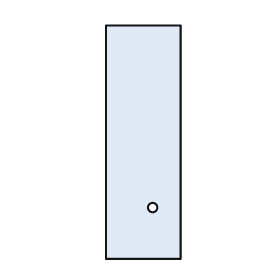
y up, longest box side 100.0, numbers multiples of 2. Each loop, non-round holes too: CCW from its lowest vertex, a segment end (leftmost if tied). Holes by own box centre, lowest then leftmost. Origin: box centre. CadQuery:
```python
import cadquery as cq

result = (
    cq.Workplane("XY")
    .moveTo(-16.0, -50.0)
    .lineTo(16.0, -50.0)
    .lineTo(16.0, 50.0)
    .lineTo(-16.0, 50.0)
    .close()
    .moveTo(4.0, -28.0)
    .circle(2.0)
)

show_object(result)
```